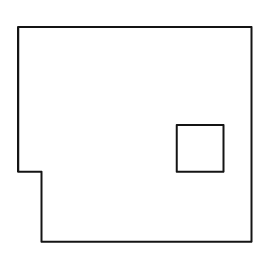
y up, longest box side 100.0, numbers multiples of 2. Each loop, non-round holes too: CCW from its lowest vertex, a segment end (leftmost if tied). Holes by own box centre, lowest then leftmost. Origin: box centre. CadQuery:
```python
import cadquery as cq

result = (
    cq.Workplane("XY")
    .moveTo(-40.0, -46.0)
    .lineTo(50.0, -46.0)
    .lineTo(50.0, 46.0)
    .lineTo(-50.0, 46.0)
    .lineTo(-50.0, -16.0)
    .lineTo(-40.0, -16.0)
    .close()
    .moveTo(18.0, -16.0)
    .lineTo(38.0, -16.0)
    .lineTo(38.0, 4.0)
    .lineTo(18.0, 4.0)
    .close()
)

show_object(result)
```